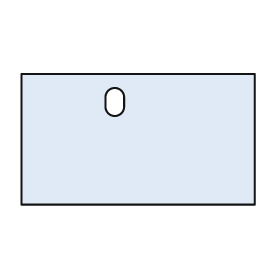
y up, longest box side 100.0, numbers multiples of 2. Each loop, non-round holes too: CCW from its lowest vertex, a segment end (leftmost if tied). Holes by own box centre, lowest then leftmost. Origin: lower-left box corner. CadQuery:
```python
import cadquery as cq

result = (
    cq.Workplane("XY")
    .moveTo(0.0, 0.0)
    .lineTo(100.0, 0.0)
    .lineTo(100.0, 56.0)
    .lineTo(0.0, 56.0)
    .close()
    .moveTo(36.0, 42.0)
    .threePointArc((40.0, 38.0), (44.0, 42.0))
    .lineTo(44.0, 46.0)
    .threePointArc((40.0, 50.0), (36.0, 46.0))
    .close()
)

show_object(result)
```